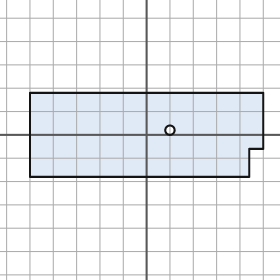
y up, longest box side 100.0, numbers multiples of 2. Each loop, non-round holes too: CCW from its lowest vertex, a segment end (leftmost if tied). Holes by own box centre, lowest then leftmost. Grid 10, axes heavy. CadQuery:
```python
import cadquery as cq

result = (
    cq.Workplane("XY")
    .moveTo(-50.0, -18.0)
    .lineTo(44.0, -18.0)
    .lineTo(44.0, -6.0)
    .lineTo(50.0, -6.0)
    .lineTo(50.0, 18.0)
    .lineTo(-50.0, 18.0)
    .close()
    .moveTo(10.0, 2.0)
    .circle(2.0)
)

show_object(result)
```